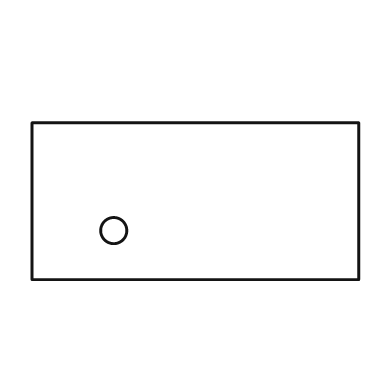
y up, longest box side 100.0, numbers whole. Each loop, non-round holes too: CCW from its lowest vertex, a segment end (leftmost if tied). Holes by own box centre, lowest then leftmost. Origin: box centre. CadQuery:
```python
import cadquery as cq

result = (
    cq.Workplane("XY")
    .moveTo(-50.0, -24.0)
    .lineTo(50.0, -24.0)
    .lineTo(50.0, 24.0)
    .lineTo(-50.0, 24.0)
    .close()
    .moveTo(-25.0, -9.0)
    .circle(4.0)
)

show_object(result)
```